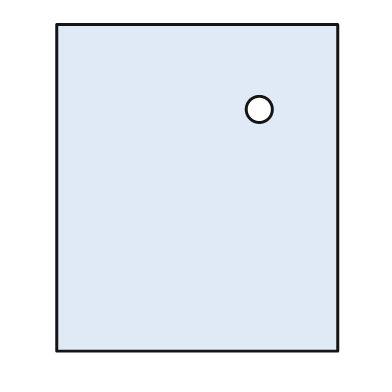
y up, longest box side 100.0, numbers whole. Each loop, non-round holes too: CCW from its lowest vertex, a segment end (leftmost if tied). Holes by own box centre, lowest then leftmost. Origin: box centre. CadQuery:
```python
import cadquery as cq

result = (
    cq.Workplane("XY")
    .moveTo(-43.0, -50.0)
    .lineTo(43.0, -50.0)
    .lineTo(43.0, 50.0)
    .lineTo(-43.0, 50.0)
    .close()
    .moveTo(19.0, 24.0)
    .circle(4.0)
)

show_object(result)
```